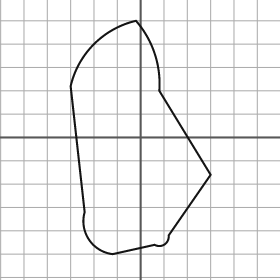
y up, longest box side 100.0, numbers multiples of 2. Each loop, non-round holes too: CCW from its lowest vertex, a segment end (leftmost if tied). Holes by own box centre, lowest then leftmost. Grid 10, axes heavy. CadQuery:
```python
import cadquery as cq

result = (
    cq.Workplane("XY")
    .moveTo(-12.0, -50.0)
    .lineTo(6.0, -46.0)
    .threePointArc((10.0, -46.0), (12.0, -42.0))
    .lineTo(30.0, -16.0)
    .lineTo(8.0, 20.0)
    .threePointArc((6.0, 36.0), (-2.0, 50.0))
    .threePointArc((-20.0, 40.0), (-30.0, 22.0))
    .lineTo(-24.0, -32.0)
    .threePointArc((-22.0, -44.0), (-12.0, -50.0))
    .close()
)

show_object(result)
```